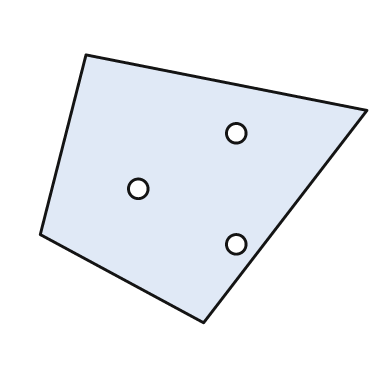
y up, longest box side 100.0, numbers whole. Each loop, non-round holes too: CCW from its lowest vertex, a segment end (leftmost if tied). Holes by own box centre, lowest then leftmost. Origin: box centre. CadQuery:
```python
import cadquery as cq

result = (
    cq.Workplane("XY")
    .moveTo(0.0, -41.0)
    .lineTo(50.0, 24.0)
    .lineTo(-36.0, 41.0)
    .lineTo(-50.0, -14.0)
    .close()
    .moveTo(10.0, -17.0)
    .circle(3.0)
    .moveTo(-20.0, 0.0)
    .circle(3.0)
    .moveTo(10.0, 17.0)
    .circle(3.0)
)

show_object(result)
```